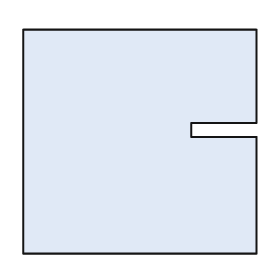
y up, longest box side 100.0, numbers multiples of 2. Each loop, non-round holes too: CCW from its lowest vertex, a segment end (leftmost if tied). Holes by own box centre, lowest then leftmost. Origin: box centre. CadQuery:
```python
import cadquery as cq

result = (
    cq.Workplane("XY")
    .moveTo(-50.0, -48.0)
    .lineTo(50.0, -48.0)
    .lineTo(50.0, 2.0)
    .lineTo(22.0, 2.0)
    .lineTo(22.0, 8.0)
    .lineTo(50.0, 8.0)
    .lineTo(50.0, 48.0)
    .lineTo(-50.0, 48.0)
    .close()
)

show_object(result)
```